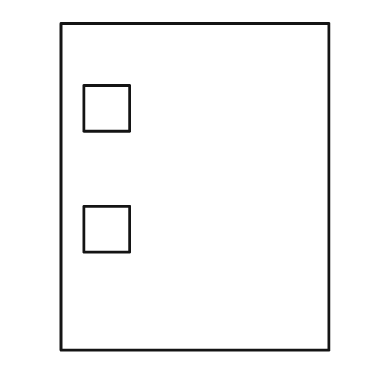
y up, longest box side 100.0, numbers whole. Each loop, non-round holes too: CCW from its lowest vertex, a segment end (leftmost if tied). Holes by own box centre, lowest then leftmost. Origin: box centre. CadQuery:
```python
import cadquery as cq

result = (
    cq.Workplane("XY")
    .moveTo(-41.0, -50.0)
    .lineTo(41.0, -50.0)
    .lineTo(41.0, 50.0)
    .lineTo(-41.0, 50.0)
    .close()
    .moveTo(-34.0, -20.0)
    .lineTo(-20.0, -20.0)
    .lineTo(-20.0, -6.0)
    .lineTo(-34.0, -6.0)
    .close()
    .moveTo(-34.0, 17.0)
    .lineTo(-20.0, 17.0)
    .lineTo(-20.0, 31.0)
    .lineTo(-34.0, 31.0)
    .close()
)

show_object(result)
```